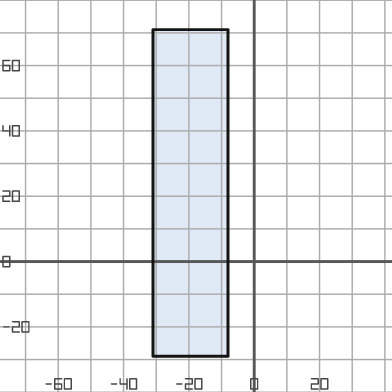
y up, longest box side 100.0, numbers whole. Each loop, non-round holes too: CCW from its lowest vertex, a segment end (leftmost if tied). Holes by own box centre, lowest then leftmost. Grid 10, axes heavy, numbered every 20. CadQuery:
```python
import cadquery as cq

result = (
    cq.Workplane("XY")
    .moveTo(-31.0, -29.0)
    .lineTo(-8.0, -29.0)
    .lineTo(-8.0, 71.0)
    .lineTo(-31.0, 71.0)
    .close()
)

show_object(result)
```